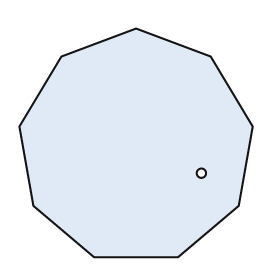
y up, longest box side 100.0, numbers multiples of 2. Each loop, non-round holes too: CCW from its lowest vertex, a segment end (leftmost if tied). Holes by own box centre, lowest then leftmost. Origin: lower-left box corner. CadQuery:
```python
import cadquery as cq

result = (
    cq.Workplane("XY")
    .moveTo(32.0, 0.0)
    .lineTo(68.0, 0.0)
    .lineTo(94.0, 22.0)
    .lineTo(100.0, 56.0)
    .lineTo(82.0, 86.0)
    .lineTo(50.0, 98.0)
    .lineTo(18.0, 86.0)
    .lineTo(0.0, 56.0)
    .lineTo(6.0, 22.0)
    .close()
    .moveTo(78.0, 36.0)
    .circle(2.0)
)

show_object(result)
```